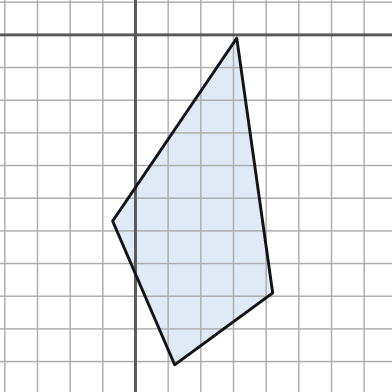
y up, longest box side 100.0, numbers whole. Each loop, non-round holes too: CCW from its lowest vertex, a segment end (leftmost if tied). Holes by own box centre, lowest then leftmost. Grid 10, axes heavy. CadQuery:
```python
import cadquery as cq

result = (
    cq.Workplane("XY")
    .moveTo(12.0, -101.0)
    .lineTo(42.0, -79.0)
    .lineTo(31.0, -1.0)
    .lineTo(-7.0, -57.0)
    .close()
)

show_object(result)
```